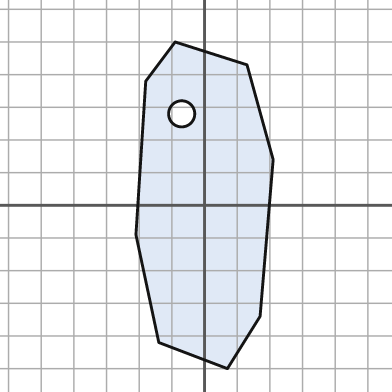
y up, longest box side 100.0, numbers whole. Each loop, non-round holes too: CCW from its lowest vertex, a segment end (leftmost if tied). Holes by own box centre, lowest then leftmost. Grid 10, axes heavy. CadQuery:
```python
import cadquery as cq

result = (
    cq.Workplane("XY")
    .moveTo(7.0, -50.0)
    .lineTo(17.0, -34.0)
    .lineTo(21.0, 14.0)
    .lineTo(13.0, 43.0)
    .lineTo(-9.0, 50.0)
    .lineTo(-18.0, 38.0)
    .lineTo(-21.0, -9.0)
    .lineTo(-14.0, -42.0)
    .close()
    .moveTo(-7.0, 28.0)
    .circle(4.0)
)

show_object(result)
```